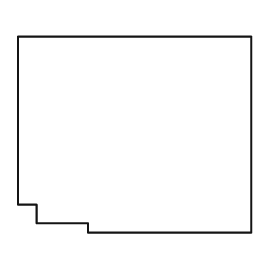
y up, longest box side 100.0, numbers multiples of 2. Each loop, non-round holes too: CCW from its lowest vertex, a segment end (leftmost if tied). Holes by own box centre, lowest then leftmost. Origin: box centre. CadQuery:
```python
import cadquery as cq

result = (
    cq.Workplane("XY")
    .moveTo(-20.0, -42.0)
    .lineTo(50.0, -42.0)
    .lineTo(50.0, 42.0)
    .lineTo(-50.0, 42.0)
    .lineTo(-50.0, -30.0)
    .lineTo(-42.0, -30.0)
    .lineTo(-42.0, -38.0)
    .lineTo(-20.0, -38.0)
    .close()
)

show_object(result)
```